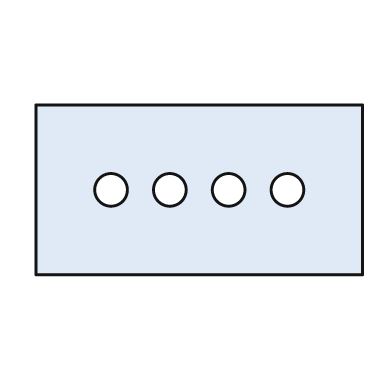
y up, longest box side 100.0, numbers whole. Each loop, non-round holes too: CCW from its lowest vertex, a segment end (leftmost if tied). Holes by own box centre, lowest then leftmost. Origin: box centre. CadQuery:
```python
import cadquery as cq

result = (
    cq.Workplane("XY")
    .moveTo(-50.0, -26.0)
    .lineTo(50.0, -26.0)
    .lineTo(50.0, 26.0)
    .lineTo(-50.0, 26.0)
    .close()
    .moveTo(-27.0, 0.0)
    .circle(5.0)
    .moveTo(-9.0, 0.0)
    .circle(5.0)
    .moveTo(9.0, 0.0)
    .circle(5.0)
    .moveTo(27.0, 0.0)
    .circle(5.0)
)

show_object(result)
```